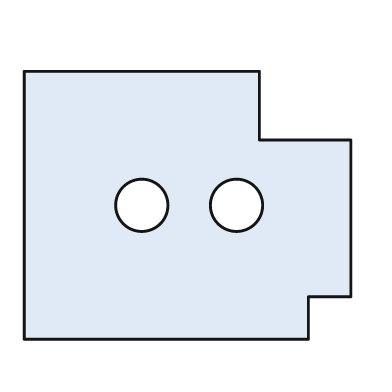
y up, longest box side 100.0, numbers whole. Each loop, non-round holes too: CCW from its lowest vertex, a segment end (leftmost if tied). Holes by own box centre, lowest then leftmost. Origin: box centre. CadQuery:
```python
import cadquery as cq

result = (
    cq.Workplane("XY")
    .moveTo(-50.0, -41.0)
    .lineTo(37.0, -41.0)
    .lineTo(37.0, -28.0)
    .lineTo(50.0, -28.0)
    .lineTo(50.0, 20.0)
    .lineTo(22.0, 20.0)
    .lineTo(22.0, 41.0)
    .lineTo(-50.0, 41.0)
    .close()
    .moveTo(-14.0, 0.0)
    .circle(8.0)
    .moveTo(15.0, 0.0)
    .circle(8.0)
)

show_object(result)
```